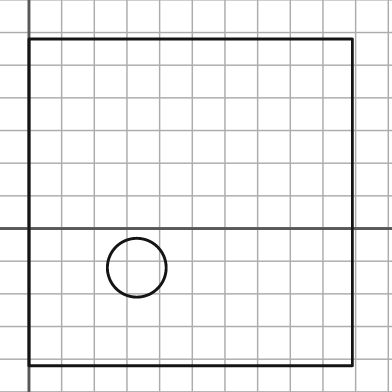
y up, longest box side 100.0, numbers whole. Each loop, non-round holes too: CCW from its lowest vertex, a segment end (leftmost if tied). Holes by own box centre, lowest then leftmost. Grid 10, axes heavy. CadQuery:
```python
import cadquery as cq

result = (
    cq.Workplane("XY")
    .moveTo(0.0, -42.0)
    .lineTo(99.0, -42.0)
    .lineTo(99.0, 58.0)
    .lineTo(0.0, 58.0)
    .close()
    .moveTo(33.0, -12.0)
    .circle(9.0)
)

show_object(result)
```